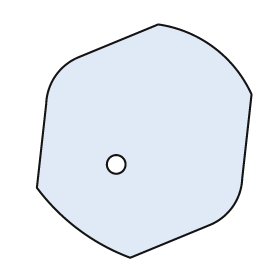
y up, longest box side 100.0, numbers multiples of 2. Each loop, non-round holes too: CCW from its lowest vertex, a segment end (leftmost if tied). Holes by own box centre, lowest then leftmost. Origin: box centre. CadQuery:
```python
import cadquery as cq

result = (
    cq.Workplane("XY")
    .moveTo(-6.0, -50.0)
    .lineTo(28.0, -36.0)
    .threePointArc((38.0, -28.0), (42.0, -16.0))
    .lineTo(46.0, 20.0)
    .threePointArc((30.0, 40.0), (6.0, 50.0))
    .lineTo(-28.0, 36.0)
    .threePointArc((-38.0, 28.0), (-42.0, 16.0))
    .lineTo(-46.0, -20.0)
    .threePointArc((-28.0, -38.0), (-6.0, -50.0))
    .close()
    .moveTo(-12.0, -10.0)
    .circle(4.0)
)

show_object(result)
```